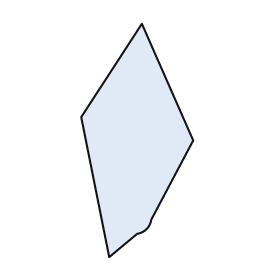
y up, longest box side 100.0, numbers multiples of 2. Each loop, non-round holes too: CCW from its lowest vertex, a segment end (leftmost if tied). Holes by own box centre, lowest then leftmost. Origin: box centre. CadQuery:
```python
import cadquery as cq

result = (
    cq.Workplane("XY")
    .moveTo(-12.0, -50.0)
    .lineTo(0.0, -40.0)
    .threePointArc((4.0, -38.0), (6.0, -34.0))
    .lineTo(24.0, 0.0)
    .lineTo(2.0, 50.0)
    .lineTo(-24.0, 10.0)
    .close()
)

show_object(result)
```